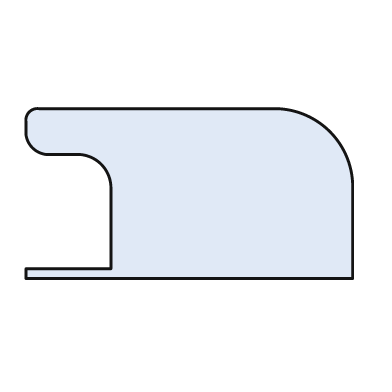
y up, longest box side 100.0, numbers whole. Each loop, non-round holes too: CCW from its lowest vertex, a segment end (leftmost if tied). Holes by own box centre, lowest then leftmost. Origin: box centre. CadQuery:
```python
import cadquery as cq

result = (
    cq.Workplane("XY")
    .moveTo(-50.0, -26.0)
    .lineTo(50.0, -26.0)
    .lineTo(50.0, 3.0)
    .threePointArc((43.0, 19.0), (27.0, 26.0))
    .lineTo(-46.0, 26.0)
    .threePointArc((-49.0, 25.0), (-50.0, 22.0))
    .lineTo(-50.0, 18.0)
    .threePointArc((-48.0, 14.0), (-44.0, 12.0))
    .lineTo(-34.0, 12.0)
    .threePointArc((-27.0, 9.0), (-24.0, 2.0))
    .lineTo(-24.0, -23.0)
    .lineTo(-50.0, -23.0)
    .close()
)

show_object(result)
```